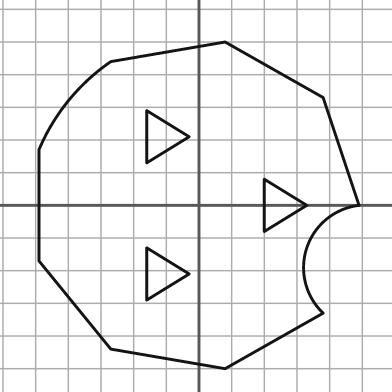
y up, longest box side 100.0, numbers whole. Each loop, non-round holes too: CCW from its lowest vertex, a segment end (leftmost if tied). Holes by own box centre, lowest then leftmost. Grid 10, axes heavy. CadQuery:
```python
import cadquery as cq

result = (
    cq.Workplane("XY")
    .moveTo(8.0, -50.0)
    .lineTo(38.0, -33.0)
    .threePointArc((33.0, -13.0), (49.0, 0.0))
    .lineTo(38.0, 33.0)
    .lineTo(8.0, 50.0)
    .lineTo(-27.0, 44.0)
    .threePointArc((-40.0, 32.0), (-49.0, 17.0))
    .lineTo(-49.0, -17.0)
    .lineTo(-27.0, -44.0)
    .close()
    .moveTo(-16.0, -29.0)
    .lineTo(-3.0, -21.0)
    .lineTo(-16.0, -13.0)
    .close()
    .moveTo(20.0, -8.0)
    .lineTo(33.0, 0.0)
    .lineTo(20.0, 8.0)
    .close()
    .moveTo(-16.0, 13.0)
    .lineTo(-3.0, 21.0)
    .lineTo(-16.0, 29.0)
    .close()
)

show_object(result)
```